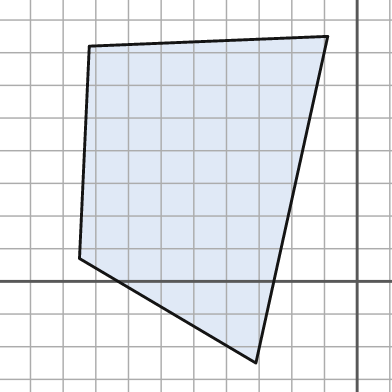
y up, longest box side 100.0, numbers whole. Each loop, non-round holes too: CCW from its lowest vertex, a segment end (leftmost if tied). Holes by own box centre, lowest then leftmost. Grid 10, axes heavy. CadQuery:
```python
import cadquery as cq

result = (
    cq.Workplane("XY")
    .moveTo(-31.0, -25.0)
    .lineTo(-9.0, 75.0)
    .lineTo(-82.0, 72.0)
    .lineTo(-85.0, 7.0)
    .close()
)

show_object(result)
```